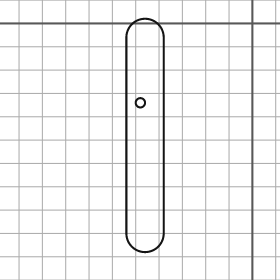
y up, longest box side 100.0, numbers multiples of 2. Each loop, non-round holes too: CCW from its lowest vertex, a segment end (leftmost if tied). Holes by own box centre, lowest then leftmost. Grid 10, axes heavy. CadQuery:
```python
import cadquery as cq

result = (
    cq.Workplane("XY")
    .moveTo(-54.0, -90.0)
    .threePointArc((-46.0, -98.0), (-38.0, -90.0))
    .lineTo(-38.0, -6.0)
    .threePointArc((-46.0, 2.0), (-54.0, -6.0))
    .close()
    .moveTo(-48.0, -34.0)
    .circle(2.0)
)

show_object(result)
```